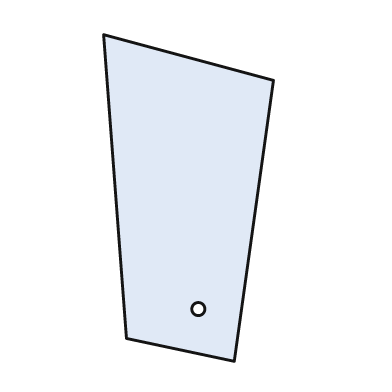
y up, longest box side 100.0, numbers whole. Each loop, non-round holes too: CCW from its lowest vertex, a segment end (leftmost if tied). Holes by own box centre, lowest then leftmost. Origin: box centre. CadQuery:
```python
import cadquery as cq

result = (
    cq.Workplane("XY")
    .moveTo(14.0, -50.0)
    .lineTo(26.0, 36.0)
    .lineTo(-26.0, 50.0)
    .lineTo(-19.0, -43.0)
    .close()
    .moveTo(3.0, -34.0)
    .circle(2.0)
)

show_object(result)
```